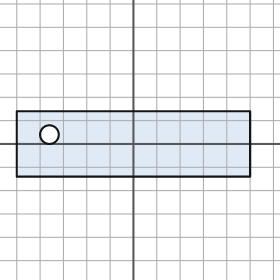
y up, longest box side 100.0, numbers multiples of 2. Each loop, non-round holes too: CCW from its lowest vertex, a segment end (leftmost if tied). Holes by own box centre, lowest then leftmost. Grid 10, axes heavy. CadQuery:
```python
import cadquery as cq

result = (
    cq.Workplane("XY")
    .moveTo(-50.0, -14.0)
    .lineTo(50.0, -14.0)
    .lineTo(50.0, 14.0)
    .lineTo(-50.0, 14.0)
    .close()
    .moveTo(-36.0, 4.0)
    .circle(4.0)
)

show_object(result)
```